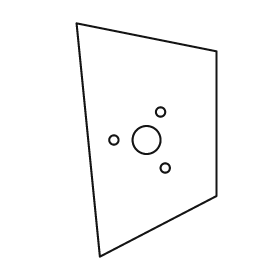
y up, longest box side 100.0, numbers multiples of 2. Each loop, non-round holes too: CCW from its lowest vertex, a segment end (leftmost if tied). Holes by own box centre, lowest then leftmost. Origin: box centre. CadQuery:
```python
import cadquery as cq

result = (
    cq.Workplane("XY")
    .moveTo(-20.0, -50.0)
    .lineTo(30.0, -24.0)
    .lineTo(30.0, 38.0)
    .lineTo(-30.0, 50.0)
    .close()
    .moveTo(8.0, -12.0)
    .circle(2.0)
    .moveTo(-14.0, 0.0)
    .circle(2.0)
    .moveTo(0.0, 0.0)
    .circle(6.0)
    .moveTo(6.0, 12.0)
    .circle(2.0)
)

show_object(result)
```